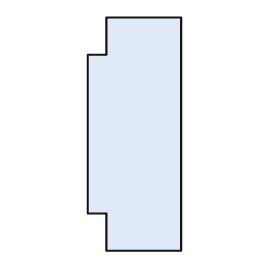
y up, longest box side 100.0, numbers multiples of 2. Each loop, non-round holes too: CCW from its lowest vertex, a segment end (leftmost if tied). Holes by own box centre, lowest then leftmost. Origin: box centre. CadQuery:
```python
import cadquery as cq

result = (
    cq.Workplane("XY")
    .moveTo(-12.0, -50.0)
    .lineTo(20.0, -50.0)
    .lineTo(20.0, 50.0)
    .lineTo(-12.0, 50.0)
    .lineTo(-12.0, 34.0)
    .lineTo(-20.0, 34.0)
    .lineTo(-20.0, -34.0)
    .lineTo(-12.0, -34.0)
    .close()
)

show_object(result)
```